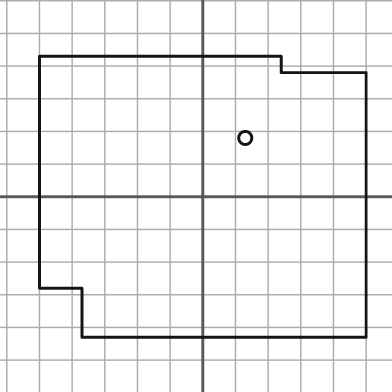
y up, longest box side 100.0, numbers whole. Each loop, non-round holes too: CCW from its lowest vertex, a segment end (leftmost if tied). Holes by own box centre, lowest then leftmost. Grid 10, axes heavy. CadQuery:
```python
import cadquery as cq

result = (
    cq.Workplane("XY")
    .moveTo(-37.0, -43.0)
    .lineTo(50.0, -43.0)
    .lineTo(50.0, 38.0)
    .lineTo(24.0, 38.0)
    .lineTo(24.0, 43.0)
    .lineTo(-50.0, 43.0)
    .lineTo(-50.0, -28.0)
    .lineTo(-37.0, -28.0)
    .close()
    .moveTo(13.0, 18.0)
    .circle(2.0)
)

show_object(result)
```